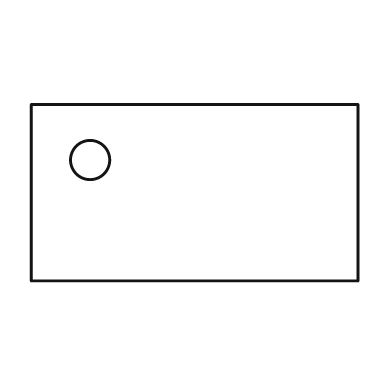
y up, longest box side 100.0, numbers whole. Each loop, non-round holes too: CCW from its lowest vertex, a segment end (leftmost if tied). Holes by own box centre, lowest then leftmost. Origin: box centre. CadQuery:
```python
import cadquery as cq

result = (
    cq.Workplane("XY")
    .moveTo(-50.0, -27.0)
    .lineTo(50.0, -27.0)
    .lineTo(50.0, 27.0)
    .lineTo(-50.0, 27.0)
    .close()
    .moveTo(-32.0, 10.0)
    .circle(6.0)
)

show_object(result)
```